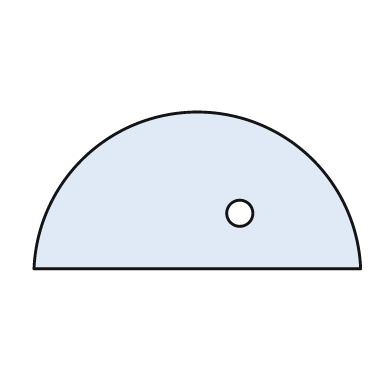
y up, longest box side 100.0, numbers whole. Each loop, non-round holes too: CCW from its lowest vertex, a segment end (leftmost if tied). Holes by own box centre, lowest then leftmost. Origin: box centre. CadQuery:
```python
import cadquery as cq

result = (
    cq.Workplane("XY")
    .moveTo(-50.0, -24.0)
    .lineTo(50.0, -24.0)
    .threePointArc((0.0, 24.0), (-50.0, -24.0))
    .close()
    .moveTo(13.0, -7.0)
    .circle(4.0)
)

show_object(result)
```